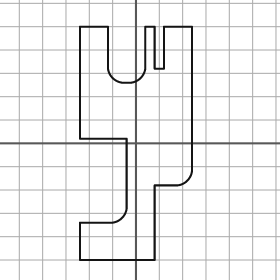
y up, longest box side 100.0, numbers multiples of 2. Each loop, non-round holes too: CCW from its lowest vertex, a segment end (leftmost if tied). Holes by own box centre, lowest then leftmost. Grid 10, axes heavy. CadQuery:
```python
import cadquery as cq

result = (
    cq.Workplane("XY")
    .moveTo(-24.0, -50.0)
    .lineTo(8.0, -50.0)
    .lineTo(8.0, -18.0)
    .lineTo(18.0, -18.0)
    .threePointArc((22.0, -16.0), (24.0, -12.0))
    .lineTo(24.0, 50.0)
    .lineTo(12.0, 50.0)
    .lineTo(12.0, 32.0)
    .lineTo(8.0, 32.0)
    .lineTo(8.0, 50.0)
    .lineTo(4.0, 50.0)
    .lineTo(4.0, 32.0)
    .threePointArc((2.0, 28.0), (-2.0, 26.0))
    .lineTo(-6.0, 26.0)
    .threePointArc((-10.0, 28.0), (-12.0, 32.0))
    .lineTo(-12.0, 50.0)
    .lineTo(-24.0, 50.0)
    .lineTo(-24.0, 2.0)
    .lineTo(-4.0, 2.0)
    .lineTo(-4.0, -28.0)
    .threePointArc((-6.0, -32.0), (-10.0, -34.0))
    .lineTo(-24.0, -34.0)
    .close()
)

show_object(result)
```